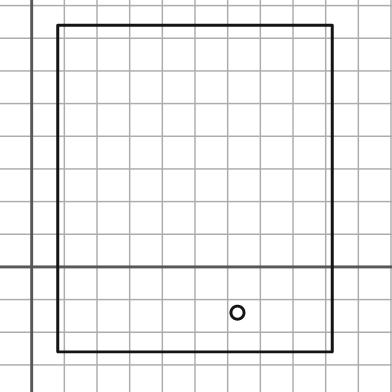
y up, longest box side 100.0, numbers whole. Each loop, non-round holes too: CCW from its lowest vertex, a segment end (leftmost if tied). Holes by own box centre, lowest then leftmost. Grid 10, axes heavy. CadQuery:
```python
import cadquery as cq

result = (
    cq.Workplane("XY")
    .moveTo(8.0, -26.0)
    .lineTo(92.0, -26.0)
    .lineTo(92.0, 74.0)
    .lineTo(8.0, 74.0)
    .close()
    .moveTo(63.0, -14.0)
    .circle(2.0)
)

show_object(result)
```